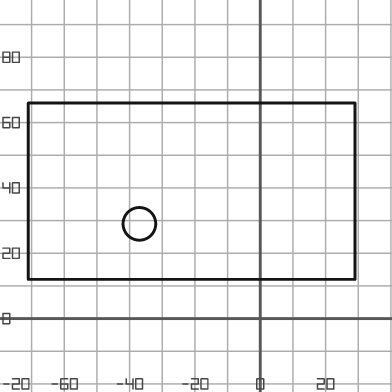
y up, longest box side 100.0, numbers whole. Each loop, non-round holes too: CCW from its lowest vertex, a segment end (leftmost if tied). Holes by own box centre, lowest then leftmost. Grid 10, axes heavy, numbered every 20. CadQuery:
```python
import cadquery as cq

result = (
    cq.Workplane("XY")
    .moveTo(-71.0, 12.0)
    .lineTo(29.0, 12.0)
    .lineTo(29.0, 66.0)
    .lineTo(-71.0, 66.0)
    .close()
    .moveTo(-37.0, 29.0)
    .circle(5.0)
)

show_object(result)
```